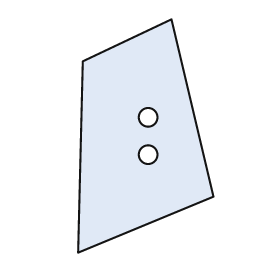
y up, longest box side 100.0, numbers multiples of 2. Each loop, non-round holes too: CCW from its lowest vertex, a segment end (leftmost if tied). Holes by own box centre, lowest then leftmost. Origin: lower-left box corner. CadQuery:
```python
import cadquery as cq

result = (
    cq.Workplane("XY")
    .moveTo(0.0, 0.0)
    .lineTo(58.0, 24.0)
    .lineTo(40.0, 100.0)
    .lineTo(2.0, 82.0)
    .close()
    .moveTo(30.0, 42.0)
    .circle(4.0)
    .moveTo(30.0, 58.0)
    .circle(4.0)
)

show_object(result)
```